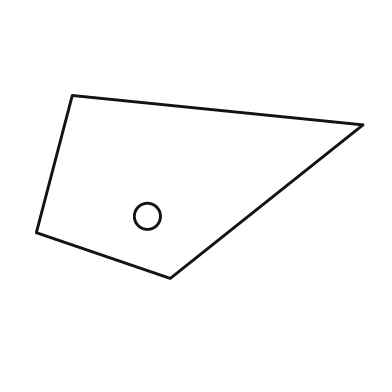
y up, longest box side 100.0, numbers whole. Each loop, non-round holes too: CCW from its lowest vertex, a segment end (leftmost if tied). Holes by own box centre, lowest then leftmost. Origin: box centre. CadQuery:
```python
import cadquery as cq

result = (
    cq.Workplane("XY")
    .moveTo(-9.0, -28.0)
    .lineTo(50.0, 19.0)
    .lineTo(-39.0, 28.0)
    .lineTo(-50.0, -14.0)
    .close()
    .moveTo(-16.0, -9.0)
    .circle(4.0)
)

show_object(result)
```